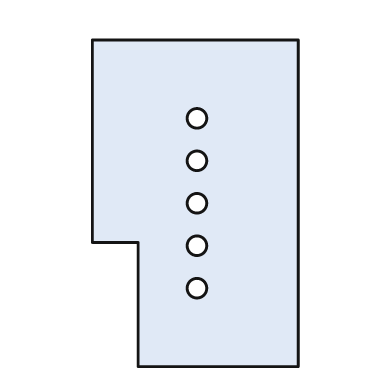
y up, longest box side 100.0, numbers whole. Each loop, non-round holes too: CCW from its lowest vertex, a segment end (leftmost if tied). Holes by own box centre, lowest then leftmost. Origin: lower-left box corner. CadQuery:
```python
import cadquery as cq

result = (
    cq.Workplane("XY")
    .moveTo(14.0, 0.0)
    .lineTo(63.0, 0.0)
    .lineTo(63.0, 100.0)
    .lineTo(0.0, 100.0)
    .lineTo(0.0, 38.0)
    .lineTo(14.0, 38.0)
    .close()
    .moveTo(32.0, 24.0)
    .circle(3.0)
    .moveTo(32.0, 37.0)
    .circle(3.0)
    .moveTo(32.0, 50.0)
    .circle(3.0)
    .moveTo(32.0, 63.0)
    .circle(3.0)
    .moveTo(32.0, 76.0)
    .circle(3.0)
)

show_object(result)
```